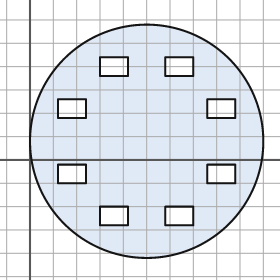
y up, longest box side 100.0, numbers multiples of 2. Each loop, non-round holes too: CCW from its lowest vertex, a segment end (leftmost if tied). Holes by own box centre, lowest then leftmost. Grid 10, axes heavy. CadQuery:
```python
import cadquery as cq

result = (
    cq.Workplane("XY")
    .moveTo(50.0, 8.0)
    .circle(50.0)
    .moveTo(30.0, -28.0)
    .lineTo(42.0, -28.0)
    .lineTo(42.0, -20.0)
    .lineTo(30.0, -20.0)
    .close()
    .moveTo(58.0, -28.0)
    .lineTo(70.0, -28.0)
    .lineTo(70.0, -20.0)
    .lineTo(58.0, -20.0)
    .close()
    .moveTo(12.0, -10.0)
    .lineTo(24.0, -10.0)
    .lineTo(24.0, -2.0)
    .lineTo(12.0, -2.0)
    .close()
    .moveTo(76.0, -10.0)
    .lineTo(88.0, -10.0)
    .lineTo(88.0, -2.0)
    .lineTo(76.0, -2.0)
    .close()
    .moveTo(12.0, 18.0)
    .lineTo(24.0, 18.0)
    .lineTo(24.0, 26.0)
    .lineTo(12.0, 26.0)
    .close()
    .moveTo(76.0, 18.0)
    .lineTo(88.0, 18.0)
    .lineTo(88.0, 26.0)
    .lineTo(76.0, 26.0)
    .close()
    .moveTo(30.0, 36.0)
    .lineTo(42.0, 36.0)
    .lineTo(42.0, 44.0)
    .lineTo(30.0, 44.0)
    .close()
    .moveTo(58.0, 36.0)
    .lineTo(70.0, 36.0)
    .lineTo(70.0, 44.0)
    .lineTo(58.0, 44.0)
    .close()
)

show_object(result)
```